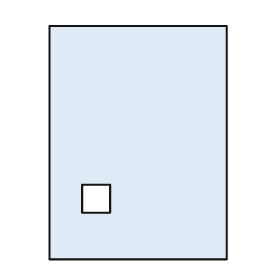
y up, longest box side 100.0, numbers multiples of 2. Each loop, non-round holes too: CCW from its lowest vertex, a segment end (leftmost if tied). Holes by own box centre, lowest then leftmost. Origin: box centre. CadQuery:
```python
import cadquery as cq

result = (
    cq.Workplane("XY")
    .moveTo(-38.0, -50.0)
    .lineTo(38.0, -50.0)
    .lineTo(38.0, 50.0)
    .lineTo(-38.0, 50.0)
    .close()
    .moveTo(-24.0, -30.0)
    .lineTo(-12.0, -30.0)
    .lineTo(-12.0, -18.0)
    .lineTo(-24.0, -18.0)
    .close()
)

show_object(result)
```